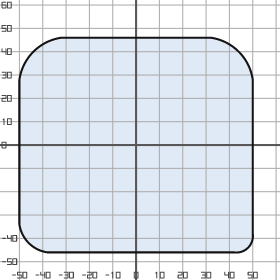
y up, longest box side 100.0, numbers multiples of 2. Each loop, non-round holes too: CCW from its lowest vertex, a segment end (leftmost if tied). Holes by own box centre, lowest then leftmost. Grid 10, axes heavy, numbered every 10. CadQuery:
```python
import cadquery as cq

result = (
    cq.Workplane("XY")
    .moveTo(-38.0, -46.0)
    .lineTo(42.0, -46.0)
    .threePointArc((48.0, -44.0), (50.0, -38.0))
    .lineTo(50.0, 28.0)
    .threePointArc((44.0, 40.0), (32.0, 46.0))
    .lineTo(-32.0, 46.0)
    .threePointArc((-44.0, 40.0), (-50.0, 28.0))
    .lineTo(-50.0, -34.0)
    .threePointArc((-46.0, -42.0), (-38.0, -46.0))
    .close()
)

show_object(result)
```